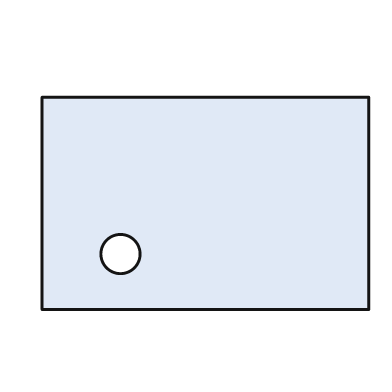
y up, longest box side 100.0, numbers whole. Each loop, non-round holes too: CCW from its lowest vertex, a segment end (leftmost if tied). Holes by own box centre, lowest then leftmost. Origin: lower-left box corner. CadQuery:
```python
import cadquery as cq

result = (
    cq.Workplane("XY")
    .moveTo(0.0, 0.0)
    .lineTo(100.0, 0.0)
    .lineTo(100.0, 65.0)
    .lineTo(0.0, 65.0)
    .close()
    .moveTo(24.0, 17.0)
    .circle(6.0)
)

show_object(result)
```